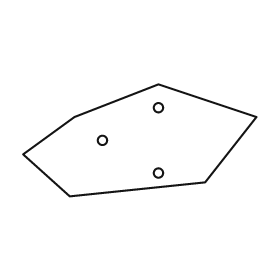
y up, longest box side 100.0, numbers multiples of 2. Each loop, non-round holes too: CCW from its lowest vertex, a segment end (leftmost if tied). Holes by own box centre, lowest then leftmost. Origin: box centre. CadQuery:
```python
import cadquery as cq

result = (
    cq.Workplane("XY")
    .moveTo(-30.0, -24.0)
    .lineTo(28.0, -18.0)
    .lineTo(50.0, 10.0)
    .lineTo(8.0, 24.0)
    .lineTo(-28.0, 10.0)
    .lineTo(-50.0, -6.0)
    .close()
    .moveTo(8.0, -14.0)
    .circle(2.0)
    .moveTo(-16.0, 0.0)
    .circle(2.0)
    .moveTo(8.0, 14.0)
    .circle(2.0)
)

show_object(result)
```